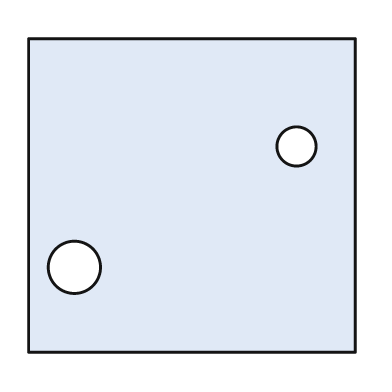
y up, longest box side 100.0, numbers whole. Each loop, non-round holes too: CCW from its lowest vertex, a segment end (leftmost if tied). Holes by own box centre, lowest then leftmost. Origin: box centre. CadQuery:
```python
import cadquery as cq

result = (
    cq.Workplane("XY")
    .moveTo(-50.0, -48.0)
    .lineTo(50.0, -48.0)
    .lineTo(50.0, 48.0)
    .lineTo(-50.0, 48.0)
    .close()
    .moveTo(-36.0, -22.0)
    .circle(8.0)
    .moveTo(32.0, 15.0)
    .circle(6.0)
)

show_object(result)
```